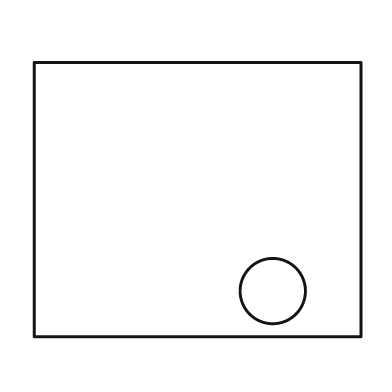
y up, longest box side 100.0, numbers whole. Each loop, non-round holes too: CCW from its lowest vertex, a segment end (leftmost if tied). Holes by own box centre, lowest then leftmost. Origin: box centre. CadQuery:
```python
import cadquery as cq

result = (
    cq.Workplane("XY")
    .moveTo(-50.0, -42.0)
    .lineTo(50.0, -42.0)
    .lineTo(50.0, 42.0)
    .lineTo(-50.0, 42.0)
    .close()
    .moveTo(23.0, -28.0)
    .circle(10.0)
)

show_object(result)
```